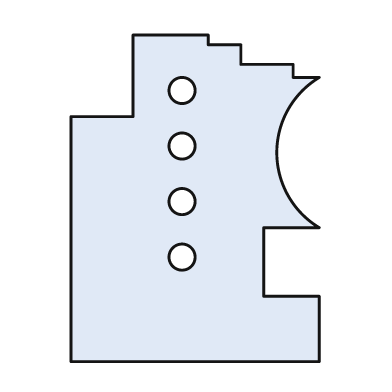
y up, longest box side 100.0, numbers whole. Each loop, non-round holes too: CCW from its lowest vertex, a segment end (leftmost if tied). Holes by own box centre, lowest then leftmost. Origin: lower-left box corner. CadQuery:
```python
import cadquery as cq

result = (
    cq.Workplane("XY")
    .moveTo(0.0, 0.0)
    .lineTo(76.0, 0.0)
    .lineTo(76.0, 20.0)
    .lineTo(59.0, 20.0)
    .lineTo(59.0, 41.0)
    .lineTo(76.0, 41.0)
    .threePointArc((63.0, 64.0), (76.0, 87.0))
    .lineTo(68.0, 87.0)
    .lineTo(68.0, 91.0)
    .lineTo(52.0, 91.0)
    .lineTo(52.0, 97.0)
    .lineTo(42.0, 97.0)
    .lineTo(42.0, 100.0)
    .lineTo(19.0, 100.0)
    .lineTo(19.0, 75.0)
    .lineTo(0.0, 75.0)
    .close()
    .moveTo(34.0, 32.0)
    .circle(4.0)
    .moveTo(34.0, 49.0)
    .circle(4.0)
    .moveTo(34.0, 66.0)
    .circle(4.0)
    .moveTo(34.0, 83.0)
    .circle(4.0)
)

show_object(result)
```